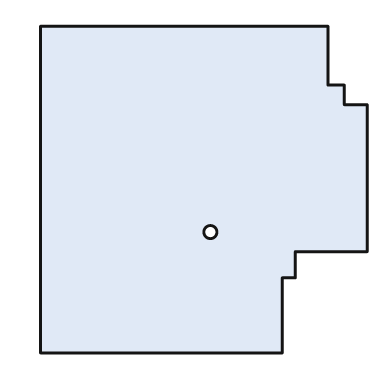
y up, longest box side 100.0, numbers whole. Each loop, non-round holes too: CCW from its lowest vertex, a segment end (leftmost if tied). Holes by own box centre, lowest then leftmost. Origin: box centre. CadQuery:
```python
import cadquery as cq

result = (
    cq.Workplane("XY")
    .moveTo(-50.0, -50.0)
    .lineTo(24.0, -50.0)
    .lineTo(24.0, -27.0)
    .lineTo(28.0, -27.0)
    .lineTo(28.0, -19.0)
    .lineTo(50.0, -19.0)
    .lineTo(50.0, 26.0)
    .lineTo(43.0, 26.0)
    .lineTo(43.0, 32.0)
    .lineTo(38.0, 32.0)
    .lineTo(38.0, 50.0)
    .lineTo(-50.0, 50.0)
    .close()
    .moveTo(2.0, -13.0)
    .circle(2.0)
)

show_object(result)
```